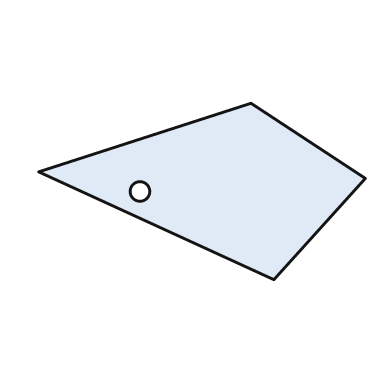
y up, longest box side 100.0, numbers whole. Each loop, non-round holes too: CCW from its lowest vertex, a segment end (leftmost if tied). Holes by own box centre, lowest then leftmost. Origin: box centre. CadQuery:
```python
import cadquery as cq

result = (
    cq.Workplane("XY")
    .moveTo(22.0, -27.0)
    .lineTo(50.0, 4.0)
    .lineTo(15.0, 27.0)
    .lineTo(-50.0, 6.0)
    .close()
    .moveTo(-19.0, 0.0)
    .circle(3.0)
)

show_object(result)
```